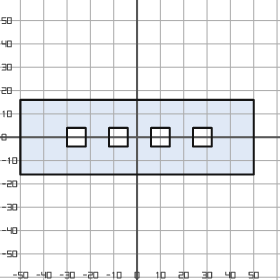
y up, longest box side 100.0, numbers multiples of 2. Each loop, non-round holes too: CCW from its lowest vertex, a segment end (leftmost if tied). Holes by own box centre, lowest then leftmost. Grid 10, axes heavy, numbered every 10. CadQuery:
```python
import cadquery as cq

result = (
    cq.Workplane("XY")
    .moveTo(-50.0, -16.0)
    .lineTo(50.0, -16.0)
    .lineTo(50.0, 16.0)
    .lineTo(-50.0, 16.0)
    .close()
    .moveTo(-30.0, -4.0)
    .lineTo(-22.0, -4.0)
    .lineTo(-22.0, 4.0)
    .lineTo(-30.0, 4.0)
    .close()
    .moveTo(-12.0, -4.0)
    .lineTo(-4.0, -4.0)
    .lineTo(-4.0, 4.0)
    .lineTo(-12.0, 4.0)
    .close()
    .moveTo(6.0, -4.0)
    .lineTo(14.0, -4.0)
    .lineTo(14.0, 4.0)
    .lineTo(6.0, 4.0)
    .close()
    .moveTo(24.0, -4.0)
    .lineTo(32.0, -4.0)
    .lineTo(32.0, 4.0)
    .lineTo(24.0, 4.0)
    .close()
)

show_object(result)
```